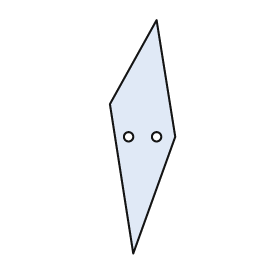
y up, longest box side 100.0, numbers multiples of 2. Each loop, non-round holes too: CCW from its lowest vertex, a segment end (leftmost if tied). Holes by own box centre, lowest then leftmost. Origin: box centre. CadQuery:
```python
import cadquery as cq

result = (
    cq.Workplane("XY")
    .moveTo(-4.0, -50.0)
    .lineTo(14.0, 0.0)
    .lineTo(6.0, 50.0)
    .lineTo(-14.0, 14.0)
    .close()
    .moveTo(-6.0, 0.0)
    .circle(2.0)
    .moveTo(6.0, 0.0)
    .circle(2.0)
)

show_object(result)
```